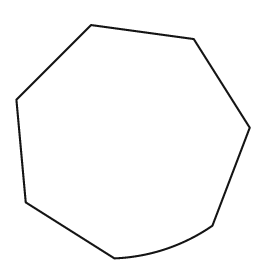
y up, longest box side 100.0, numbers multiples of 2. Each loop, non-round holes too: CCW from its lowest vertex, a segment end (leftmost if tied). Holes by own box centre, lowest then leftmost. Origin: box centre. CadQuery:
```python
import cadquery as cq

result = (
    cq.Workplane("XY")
    .moveTo(-8.0, -50.0)
    .threePointArc((14.0, -46.0), (34.0, -36.0))
    .lineTo(50.0, 6.0)
    .lineTo(26.0, 44.0)
    .lineTo(-18.0, 50.0)
    .lineTo(-50.0, 18.0)
    .lineTo(-46.0, -26.0)
    .close()
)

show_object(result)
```